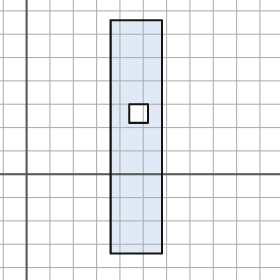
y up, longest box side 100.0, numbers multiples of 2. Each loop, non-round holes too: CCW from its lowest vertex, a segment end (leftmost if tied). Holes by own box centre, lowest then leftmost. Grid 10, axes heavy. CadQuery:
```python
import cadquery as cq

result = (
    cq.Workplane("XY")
    .moveTo(36.0, -34.0)
    .lineTo(58.0, -34.0)
    .lineTo(58.0, 66.0)
    .lineTo(36.0, 66.0)
    .close()
    .moveTo(44.0, 22.0)
    .lineTo(52.0, 22.0)
    .lineTo(52.0, 30.0)
    .lineTo(44.0, 30.0)
    .close()
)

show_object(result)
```